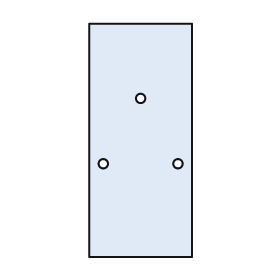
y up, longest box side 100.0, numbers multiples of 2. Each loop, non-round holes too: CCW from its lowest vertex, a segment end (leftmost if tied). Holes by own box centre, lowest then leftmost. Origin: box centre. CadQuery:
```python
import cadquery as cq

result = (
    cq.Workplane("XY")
    .moveTo(-22.0, -50.0)
    .lineTo(22.0, -50.0)
    .lineTo(22.0, 50.0)
    .lineTo(-22.0, 50.0)
    .close()
    .moveTo(-16.0, -10.0)
    .circle(2.0)
    .moveTo(16.0, -10.0)
    .circle(2.0)
    .moveTo(0.0, 18.0)
    .circle(2.0)
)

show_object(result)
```